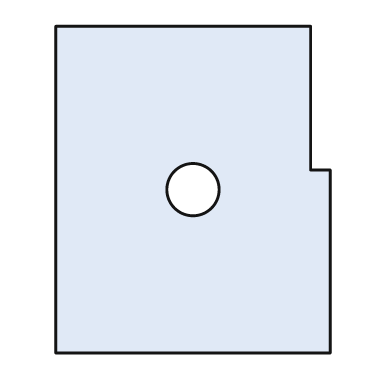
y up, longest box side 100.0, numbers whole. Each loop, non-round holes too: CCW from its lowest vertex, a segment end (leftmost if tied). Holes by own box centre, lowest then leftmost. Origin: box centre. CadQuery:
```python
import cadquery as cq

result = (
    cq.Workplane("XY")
    .moveTo(-42.0, -50.0)
    .lineTo(42.0, -50.0)
    .lineTo(42.0, 6.0)
    .lineTo(36.0, 6.0)
    .lineTo(36.0, 50.0)
    .lineTo(-42.0, 50.0)
    .close()
    .moveTo(0.0, 0.0)
    .circle(8.0)
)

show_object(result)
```